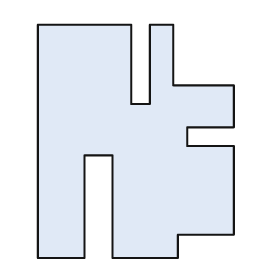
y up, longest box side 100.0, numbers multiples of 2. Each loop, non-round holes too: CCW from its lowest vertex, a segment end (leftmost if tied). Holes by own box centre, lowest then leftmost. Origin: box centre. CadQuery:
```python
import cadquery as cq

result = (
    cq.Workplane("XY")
    .moveTo(-42.0, -50.0)
    .lineTo(-22.0, -50.0)
    .lineTo(-22.0, -6.0)
    .lineTo(-10.0, -6.0)
    .lineTo(-10.0, -50.0)
    .lineTo(18.0, -50.0)
    .lineTo(18.0, -40.0)
    .lineTo(42.0, -40.0)
    .lineTo(42.0, -2.0)
    .lineTo(22.0, -2.0)
    .lineTo(22.0, 6.0)
    .lineTo(42.0, 6.0)
    .lineTo(42.0, 24.0)
    .lineTo(16.0, 24.0)
    .lineTo(16.0, 50.0)
    .lineTo(6.0, 50.0)
    .lineTo(6.0, 16.0)
    .lineTo(-2.0, 16.0)
    .lineTo(-2.0, 50.0)
    .lineTo(-42.0, 50.0)
    .close()
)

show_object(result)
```